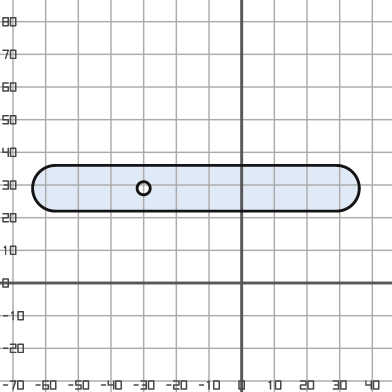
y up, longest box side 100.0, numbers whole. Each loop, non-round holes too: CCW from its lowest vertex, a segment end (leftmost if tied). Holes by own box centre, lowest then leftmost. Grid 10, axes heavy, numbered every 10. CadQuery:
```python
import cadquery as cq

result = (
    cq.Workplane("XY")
    .moveTo(-57.0, 22.0)
    .lineTo(29.0, 22.0)
    .threePointArc((36.0, 29.0), (29.0, 36.0))
    .lineTo(-57.0, 36.0)
    .threePointArc((-64.0, 29.0), (-57.0, 22.0))
    .close()
    .moveTo(-30.0, 29.0)
    .circle(2.0)
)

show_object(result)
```